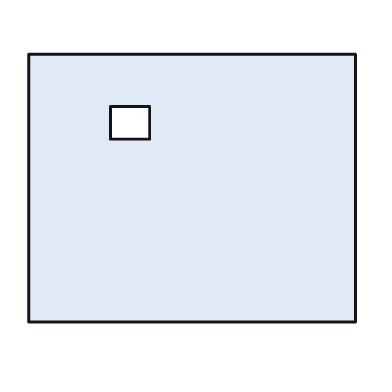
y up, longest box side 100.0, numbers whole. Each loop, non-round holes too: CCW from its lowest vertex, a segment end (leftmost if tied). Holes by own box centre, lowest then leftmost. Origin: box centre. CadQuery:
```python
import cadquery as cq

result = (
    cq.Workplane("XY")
    .moveTo(-50.0, -41.0)
    .lineTo(50.0, -41.0)
    .lineTo(50.0, 41.0)
    .lineTo(-50.0, 41.0)
    .close()
    .moveTo(-25.0, 15.0)
    .lineTo(-13.0, 15.0)
    .lineTo(-13.0, 25.0)
    .lineTo(-25.0, 25.0)
    .close()
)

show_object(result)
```